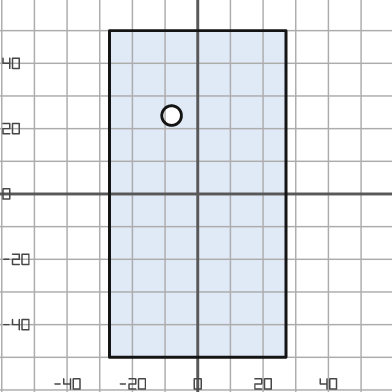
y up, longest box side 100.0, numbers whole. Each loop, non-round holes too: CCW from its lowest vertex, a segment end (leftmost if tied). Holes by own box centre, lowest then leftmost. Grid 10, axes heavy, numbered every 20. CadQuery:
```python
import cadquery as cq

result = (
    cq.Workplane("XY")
    .moveTo(-27.0, -50.0)
    .lineTo(27.0, -50.0)
    .lineTo(27.0, 50.0)
    .lineTo(-27.0, 50.0)
    .close()
    .moveTo(-8.0, 24.0)
    .circle(3.0)
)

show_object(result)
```